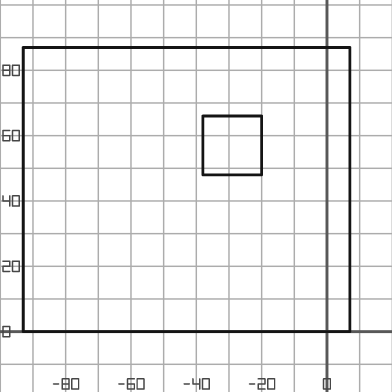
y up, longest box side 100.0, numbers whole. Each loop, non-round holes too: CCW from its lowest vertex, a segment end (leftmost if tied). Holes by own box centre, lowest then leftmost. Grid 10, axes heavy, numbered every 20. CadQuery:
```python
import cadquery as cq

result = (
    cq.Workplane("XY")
    .moveTo(-93.0, 0.0)
    .lineTo(7.0, 0.0)
    .lineTo(7.0, 87.0)
    .lineTo(-93.0, 87.0)
    .close()
    .moveTo(-38.0, 48.0)
    .lineTo(-20.0, 48.0)
    .lineTo(-20.0, 66.0)
    .lineTo(-38.0, 66.0)
    .close()
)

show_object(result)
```